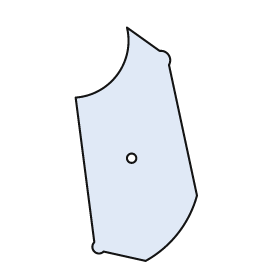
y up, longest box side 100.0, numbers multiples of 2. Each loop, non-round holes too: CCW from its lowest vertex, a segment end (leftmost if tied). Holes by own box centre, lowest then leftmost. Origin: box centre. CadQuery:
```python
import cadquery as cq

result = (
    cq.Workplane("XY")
    .moveTo(4.0, -50.0)
    .threePointArc((18.0, -38.0), (26.0, -22.0))
    .lineTo(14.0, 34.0)
    .threePointArc((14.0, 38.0), (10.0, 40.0))
    .lineTo(-4.0, 50.0)
    .threePointArc((-8.0, 30.0), (-26.0, 20.0))
    .lineTo(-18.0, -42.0)
    .threePointArc((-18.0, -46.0), (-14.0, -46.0))
    .close()
    .moveTo(-2.0, -6.0)
    .circle(2.0)
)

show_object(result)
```